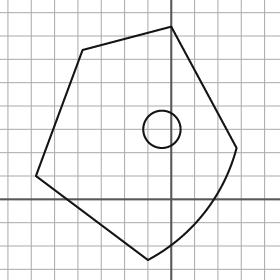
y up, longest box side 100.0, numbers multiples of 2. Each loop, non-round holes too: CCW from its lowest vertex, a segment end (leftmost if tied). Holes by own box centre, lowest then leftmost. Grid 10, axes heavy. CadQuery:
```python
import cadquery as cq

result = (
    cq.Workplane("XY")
    .moveTo(-10.0, -26.0)
    .threePointArc((14.0, -6.0), (28.0, 22.0))
    .lineTo(0.0, 74.0)
    .lineTo(-38.0, 64.0)
    .lineTo(-58.0, 10.0)
    .close()
    .moveTo(-4.0, 30.0)
    .circle(8.0)
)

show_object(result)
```